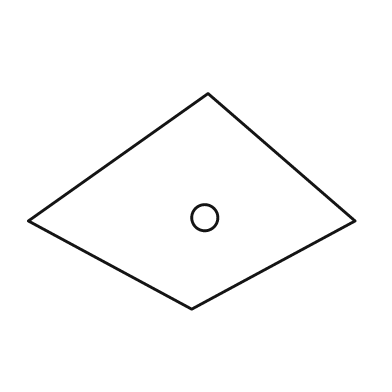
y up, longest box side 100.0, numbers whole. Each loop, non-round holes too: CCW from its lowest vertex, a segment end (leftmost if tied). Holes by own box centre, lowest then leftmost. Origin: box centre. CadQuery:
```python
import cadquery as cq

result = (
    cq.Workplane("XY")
    .moveTo(0.0, -33.0)
    .lineTo(50.0, -6.0)
    .lineTo(5.0, 33.0)
    .lineTo(-50.0, -6.0)
    .close()
    .moveTo(4.0, -5.0)
    .circle(4.0)
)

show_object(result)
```